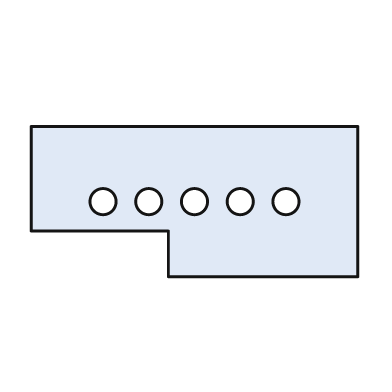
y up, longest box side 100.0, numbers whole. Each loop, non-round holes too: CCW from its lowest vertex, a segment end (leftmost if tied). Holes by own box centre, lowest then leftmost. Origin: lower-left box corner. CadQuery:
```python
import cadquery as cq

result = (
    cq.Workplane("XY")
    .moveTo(42.0, 0.0)
    .lineTo(100.0, 0.0)
    .lineTo(100.0, 46.0)
    .lineTo(0.0, 46.0)
    .lineTo(0.0, 14.0)
    .lineTo(42.0, 14.0)
    .close()
    .moveTo(22.0, 23.0)
    .circle(4.0)
    .moveTo(36.0, 23.0)
    .circle(4.0)
    .moveTo(50.0, 23.0)
    .circle(4.0)
    .moveTo(64.0, 23.0)
    .circle(4.0)
    .moveTo(78.0, 23.0)
    .circle(4.0)
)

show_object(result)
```